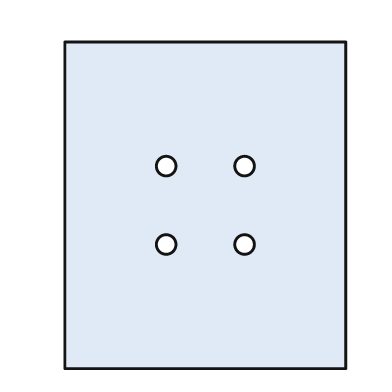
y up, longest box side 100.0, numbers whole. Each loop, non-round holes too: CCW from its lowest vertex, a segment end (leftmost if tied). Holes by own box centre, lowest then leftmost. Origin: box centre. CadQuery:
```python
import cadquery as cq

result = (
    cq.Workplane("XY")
    .moveTo(-43.0, -50.0)
    .lineTo(43.0, -50.0)
    .lineTo(43.0, 50.0)
    .lineTo(-43.0, 50.0)
    .close()
    .moveTo(-12.0, -12.0)
    .circle(3.0)
    .moveTo(12.0, -12.0)
    .circle(3.0)
    .moveTo(-12.0, 12.0)
    .circle(3.0)
    .moveTo(12.0, 12.0)
    .circle(3.0)
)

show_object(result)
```